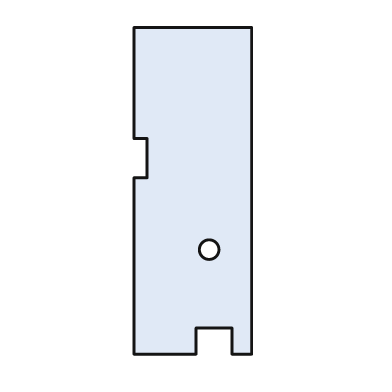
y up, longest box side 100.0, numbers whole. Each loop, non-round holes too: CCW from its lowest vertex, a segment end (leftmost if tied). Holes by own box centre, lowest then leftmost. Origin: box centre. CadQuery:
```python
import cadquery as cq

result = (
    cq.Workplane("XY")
    .moveTo(-18.0, -50.0)
    .lineTo(1.0, -50.0)
    .lineTo(1.0, -42.0)
    .lineTo(12.0, -42.0)
    .lineTo(12.0, -50.0)
    .lineTo(18.0, -50.0)
    .lineTo(18.0, 50.0)
    .lineTo(-18.0, 50.0)
    .lineTo(-18.0, 16.0)
    .lineTo(-14.0, 16.0)
    .lineTo(-14.0, 4.0)
    .lineTo(-18.0, 4.0)
    .close()
    .moveTo(5.0, -18.0)
    .circle(3.0)
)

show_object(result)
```